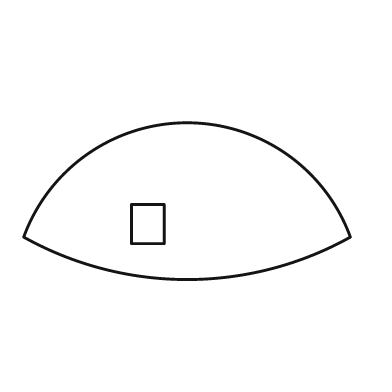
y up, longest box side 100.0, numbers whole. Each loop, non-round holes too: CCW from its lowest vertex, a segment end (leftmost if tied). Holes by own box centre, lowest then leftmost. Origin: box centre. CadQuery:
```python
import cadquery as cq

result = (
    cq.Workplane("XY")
    .moveTo(-50.0, -11.0)
    .threePointArc((0.0, -24.0), (50.0, -11.0))
    .threePointArc((0.0, 24.0), (-50.0, -11.0))
    .close()
    .moveTo(-17.0, -13.0)
    .lineTo(-7.0, -13.0)
    .lineTo(-7.0, -1.0)
    .lineTo(-17.0, -1.0)
    .close()
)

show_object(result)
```